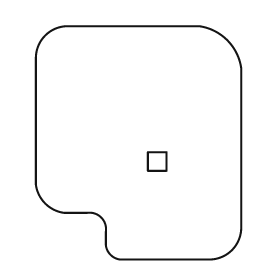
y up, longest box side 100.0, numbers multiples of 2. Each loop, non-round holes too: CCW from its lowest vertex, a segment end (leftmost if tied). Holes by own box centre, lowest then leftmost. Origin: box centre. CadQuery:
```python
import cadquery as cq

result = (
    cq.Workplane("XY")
    .moveTo(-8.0, -50.0)
    .lineTo(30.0, -50.0)
    .threePointArc((40.0, -46.0), (44.0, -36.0))
    .lineTo(44.0, 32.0)
    .threePointArc((38.0, 44.0), (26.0, 50.0))
    .lineTo(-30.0, 50.0)
    .threePointArc((-40.0, 46.0), (-44.0, 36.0))
    .lineTo(-44.0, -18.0)
    .threePointArc((-40.0, -26.0), (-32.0, -30.0))
    .lineTo(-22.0, -30.0)
    .threePointArc((-16.0, -32.0), (-14.0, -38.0))
    .lineTo(-14.0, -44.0)
    .threePointArc((-12.0, -48.0), (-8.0, -50.0))
    .close()
    .moveTo(4.0, -12.0)
    .lineTo(12.0, -12.0)
    .lineTo(12.0, -4.0)
    .lineTo(4.0, -4.0)
    .close()
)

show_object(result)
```